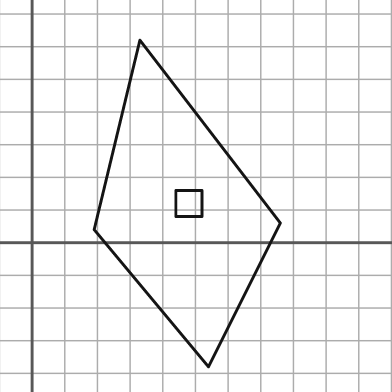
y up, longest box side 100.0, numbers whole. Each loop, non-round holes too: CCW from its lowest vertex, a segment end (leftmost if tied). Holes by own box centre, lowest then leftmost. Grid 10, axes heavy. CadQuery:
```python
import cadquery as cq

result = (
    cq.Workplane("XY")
    .moveTo(54.0, -38.0)
    .lineTo(76.0, 6.0)
    .lineTo(33.0, 62.0)
    .lineTo(19.0, 4.0)
    .close()
    .moveTo(44.0, 8.0)
    .lineTo(52.0, 8.0)
    .lineTo(52.0, 16.0)
    .lineTo(44.0, 16.0)
    .close()
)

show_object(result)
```